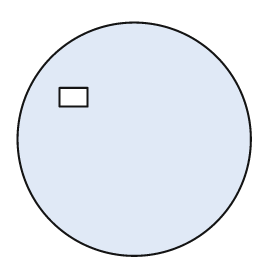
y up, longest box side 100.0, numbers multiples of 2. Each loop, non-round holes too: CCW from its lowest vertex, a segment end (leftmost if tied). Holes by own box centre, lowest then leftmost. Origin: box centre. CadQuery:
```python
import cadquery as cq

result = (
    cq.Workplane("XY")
    .moveTo(0.0, 0.0)
    .circle(50.0)
    .moveTo(-32.0, 14.0)
    .lineTo(-20.0, 14.0)
    .lineTo(-20.0, 22.0)
    .lineTo(-32.0, 22.0)
    .close()
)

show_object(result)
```